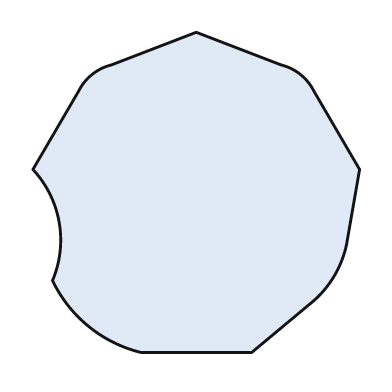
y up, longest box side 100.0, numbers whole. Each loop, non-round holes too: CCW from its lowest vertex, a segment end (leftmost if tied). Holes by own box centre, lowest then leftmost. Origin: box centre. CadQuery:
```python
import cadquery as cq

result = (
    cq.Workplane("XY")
    .moveTo(-17.0, -49.0)
    .lineTo(17.0, -49.0)
    .lineTo(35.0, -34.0)
    .threePointArc((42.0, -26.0), (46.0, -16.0))
    .lineTo(50.0, 7.0)
    .lineTo(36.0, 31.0)
    .threePointArc((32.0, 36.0), (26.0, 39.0))
    .lineTo(0.0, 49.0)
    .lineTo(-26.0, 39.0)
    .threePointArc((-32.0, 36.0), (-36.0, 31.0))
    .lineTo(-50.0, 7.0)
    .threePointArc((-42.0, -9.0), (-44.0, -27.0))
    .threePointArc((-33.0, -41.0), (-17.0, -49.0))
    .close()
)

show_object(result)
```